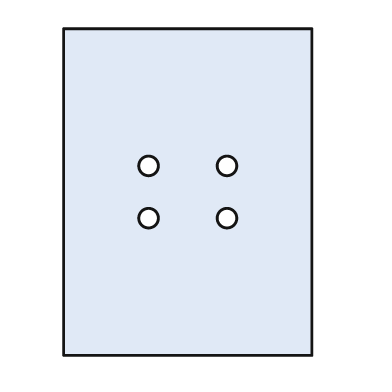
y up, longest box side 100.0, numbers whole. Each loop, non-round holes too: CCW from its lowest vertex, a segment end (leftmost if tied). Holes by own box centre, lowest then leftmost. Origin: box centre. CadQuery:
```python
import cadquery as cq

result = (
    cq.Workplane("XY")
    .moveTo(-38.0, -50.0)
    .lineTo(38.0, -50.0)
    .lineTo(38.0, 50.0)
    .lineTo(-38.0, 50.0)
    .close()
    .moveTo(-12.0, -8.0)
    .circle(3.0)
    .moveTo(12.0, -8.0)
    .circle(3.0)
    .moveTo(-12.0, 8.0)
    .circle(3.0)
    .moveTo(12.0, 8.0)
    .circle(3.0)
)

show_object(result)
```